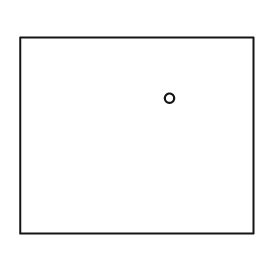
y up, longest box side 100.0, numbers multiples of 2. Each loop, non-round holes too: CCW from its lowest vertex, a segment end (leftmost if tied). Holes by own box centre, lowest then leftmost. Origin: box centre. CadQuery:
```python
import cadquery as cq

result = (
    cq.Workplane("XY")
    .moveTo(-50.0, -42.0)
    .lineTo(50.0, -42.0)
    .lineTo(50.0, 42.0)
    .lineTo(-50.0, 42.0)
    .close()
    .moveTo(14.0, 16.0)
    .circle(2.0)
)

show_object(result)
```